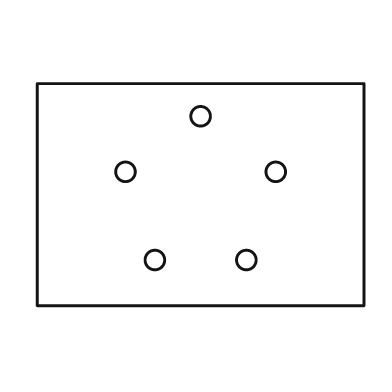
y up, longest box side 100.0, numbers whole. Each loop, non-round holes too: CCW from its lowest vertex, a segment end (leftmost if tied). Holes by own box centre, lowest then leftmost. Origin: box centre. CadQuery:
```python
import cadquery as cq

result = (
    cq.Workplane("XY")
    .moveTo(-50.0, -34.0)
    .lineTo(50.0, -34.0)
    .lineTo(50.0, 34.0)
    .lineTo(-50.0, 34.0)
    .close()
    .moveTo(-14.0, -20.0)
    .circle(3.0)
    .moveTo(14.0, -20.0)
    .circle(3.0)
    .moveTo(-23.0, 7.0)
    .circle(3.0)
    .moveTo(23.0, 7.0)
    .circle(3.0)
    .moveTo(0.0, 24.0)
    .circle(3.0)
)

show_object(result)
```